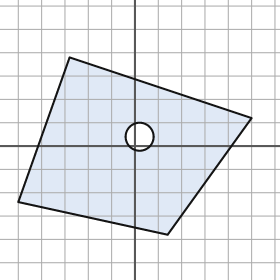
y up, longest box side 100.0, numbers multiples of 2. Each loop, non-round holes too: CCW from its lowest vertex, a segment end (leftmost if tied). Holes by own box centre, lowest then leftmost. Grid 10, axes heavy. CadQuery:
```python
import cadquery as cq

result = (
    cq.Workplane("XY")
    .moveTo(14.0, -38.0)
    .lineTo(50.0, 12.0)
    .lineTo(-28.0, 38.0)
    .lineTo(-50.0, -24.0)
    .close()
    .moveTo(2.0, 4.0)
    .circle(6.0)
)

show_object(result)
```